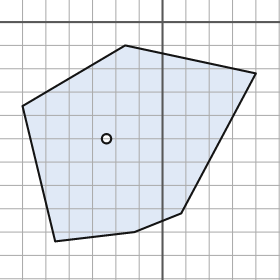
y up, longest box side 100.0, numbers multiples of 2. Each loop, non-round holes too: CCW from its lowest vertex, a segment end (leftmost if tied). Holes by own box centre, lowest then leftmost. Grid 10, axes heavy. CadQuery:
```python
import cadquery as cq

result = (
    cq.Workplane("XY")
    .moveTo(-46.0, -94.0)
    .lineTo(-12.0, -90.0)
    .lineTo(8.0, -82.0)
    .lineTo(40.0, -22.0)
    .lineTo(-16.0, -10.0)
    .lineTo(-60.0, -36.0)
    .close()
    .moveTo(-24.0, -50.0)
    .circle(2.0)
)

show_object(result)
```